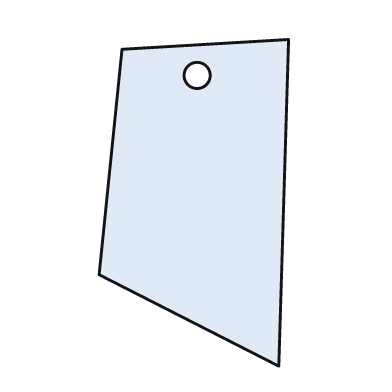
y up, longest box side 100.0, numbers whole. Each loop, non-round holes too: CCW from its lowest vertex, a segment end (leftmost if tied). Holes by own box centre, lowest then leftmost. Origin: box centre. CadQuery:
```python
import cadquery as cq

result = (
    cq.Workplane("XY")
    .moveTo(26.0, -50.0)
    .lineTo(29.0, 50.0)
    .lineTo(-22.0, 47.0)
    .lineTo(-29.0, -22.0)
    .close()
    .moveTo(1.0, 39.0)
    .circle(4.0)
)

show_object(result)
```